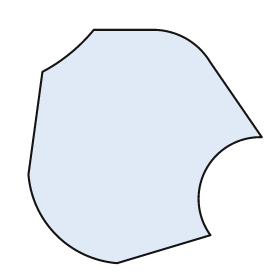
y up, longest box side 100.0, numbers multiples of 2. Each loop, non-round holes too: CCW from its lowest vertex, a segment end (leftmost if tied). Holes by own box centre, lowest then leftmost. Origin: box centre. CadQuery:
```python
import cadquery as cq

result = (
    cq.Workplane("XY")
    .moveTo(-12.0, -50.0)
    .lineTo(28.0, -38.0)
    .threePointArc((26.0, -10.0), (50.0, 4.0))
    .lineTo(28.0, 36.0)
    .threePointArc((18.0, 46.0), (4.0, 50.0))
    .lineTo(-22.0, 50.0)
    .threePointArc((-32.0, 40.0), (-44.0, 32.0))
    .lineTo(-50.0, -12.0)
    .threePointArc((-38.0, -38.0), (-12.0, -50.0))
    .close()
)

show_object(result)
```